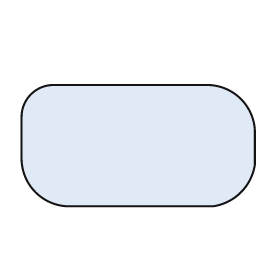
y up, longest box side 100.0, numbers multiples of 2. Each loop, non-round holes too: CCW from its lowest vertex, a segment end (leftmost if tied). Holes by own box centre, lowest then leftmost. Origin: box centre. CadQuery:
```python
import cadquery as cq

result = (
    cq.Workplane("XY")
    .moveTo(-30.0, -26.0)
    .lineTo(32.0, -26.0)
    .threePointArc((44.0, -20.0), (50.0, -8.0))
    .lineTo(50.0, 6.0)
    .threePointArc((44.0, 20.0), (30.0, 26.0))
    .lineTo(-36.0, 26.0)
    .threePointArc((-46.0, 22.0), (-50.0, 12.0))
    .lineTo(-50.0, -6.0)
    .threePointArc((-44.0, -20.0), (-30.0, -26.0))
    .close()
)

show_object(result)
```